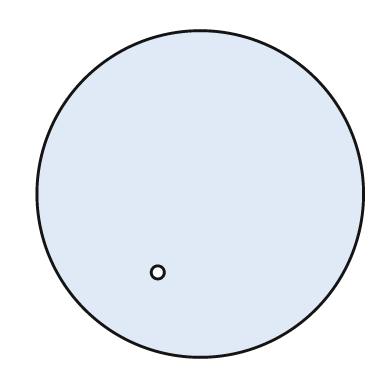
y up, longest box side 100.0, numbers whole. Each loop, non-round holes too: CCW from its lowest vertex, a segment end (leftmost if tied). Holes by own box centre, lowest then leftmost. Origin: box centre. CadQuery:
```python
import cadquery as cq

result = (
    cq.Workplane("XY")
    .moveTo(0.0, 0.0)
    .circle(50.0)
    .moveTo(-13.0, -24.0)
    .circle(2.0)
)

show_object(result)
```